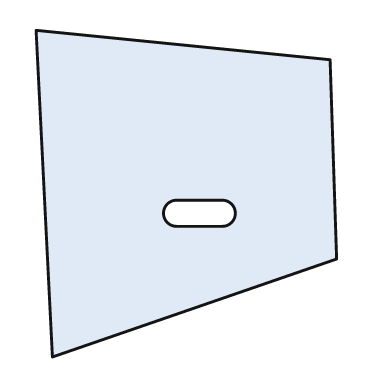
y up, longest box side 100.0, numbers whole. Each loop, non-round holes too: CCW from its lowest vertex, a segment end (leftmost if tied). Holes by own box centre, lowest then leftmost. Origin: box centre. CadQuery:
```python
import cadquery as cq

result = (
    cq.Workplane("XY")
    .moveTo(-41.0, -50.0)
    .lineTo(46.0, -20.0)
    .lineTo(44.0, 41.0)
    .lineTo(-46.0, 50.0)
    .close()
    .moveTo(-3.0, -10.0)
    .lineTo(11.0, -10.0)
    .threePointArc((15.0, -6.0), (11.0, -2.0))
    .lineTo(-3.0, -2.0)
    .threePointArc((-7.0, -6.0), (-3.0, -10.0))
    .close()
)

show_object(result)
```